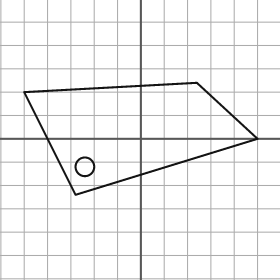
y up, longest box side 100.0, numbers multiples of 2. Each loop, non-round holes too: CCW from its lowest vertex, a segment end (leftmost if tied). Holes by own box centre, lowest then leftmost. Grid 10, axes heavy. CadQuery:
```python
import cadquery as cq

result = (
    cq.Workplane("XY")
    .moveTo(-28.0, -24.0)
    .lineTo(50.0, 0.0)
    .lineTo(24.0, 24.0)
    .lineTo(-50.0, 20.0)
    .close()
    .moveTo(-24.0, -12.0)
    .circle(4.0)
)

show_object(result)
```